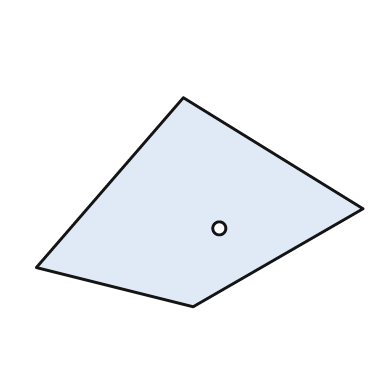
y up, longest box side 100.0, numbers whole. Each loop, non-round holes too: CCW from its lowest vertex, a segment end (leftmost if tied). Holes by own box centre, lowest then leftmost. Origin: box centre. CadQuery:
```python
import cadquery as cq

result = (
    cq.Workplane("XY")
    .moveTo(-2.0, -32.0)
    .lineTo(50.0, -2.0)
    .lineTo(-5.0, 32.0)
    .lineTo(-50.0, -20.0)
    .close()
    .moveTo(6.0, -8.0)
    .circle(2.0)
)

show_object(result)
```